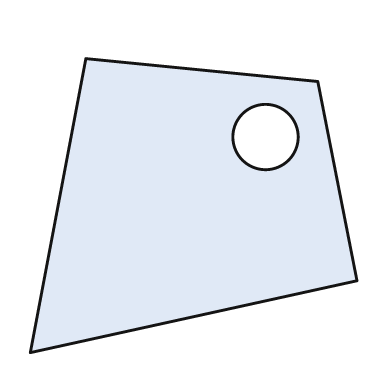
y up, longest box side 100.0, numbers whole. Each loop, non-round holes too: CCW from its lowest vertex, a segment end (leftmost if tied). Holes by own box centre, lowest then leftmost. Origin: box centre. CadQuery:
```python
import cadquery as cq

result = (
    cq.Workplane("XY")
    .moveTo(-50.0, -45.0)
    .lineTo(50.0, -23.0)
    .lineTo(38.0, 38.0)
    .lineTo(-33.0, 45.0)
    .close()
    .moveTo(22.0, 21.0)
    .circle(10.0)
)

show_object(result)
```